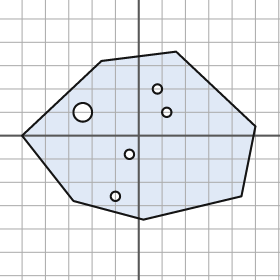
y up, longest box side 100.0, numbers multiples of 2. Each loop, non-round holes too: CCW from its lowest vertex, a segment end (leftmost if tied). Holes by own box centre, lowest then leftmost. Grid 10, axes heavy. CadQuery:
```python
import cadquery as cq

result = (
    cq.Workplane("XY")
    .moveTo(2.0, -36.0)
    .lineTo(44.0, -26.0)
    .lineTo(50.0, 4.0)
    .lineTo(16.0, 36.0)
    .lineTo(-16.0, 32.0)
    .lineTo(-50.0, 0.0)
    .lineTo(-28.0, -28.0)
    .close()
    .moveTo(-10.0, -26.0)
    .circle(2.0)
    .moveTo(-4.0, -8.0)
    .circle(2.0)
    .moveTo(-24.0, 10.0)
    .circle(4.0)
    .moveTo(12.0, 10.0)
    .circle(2.0)
    .moveTo(8.0, 20.0)
    .circle(2.0)
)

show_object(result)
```